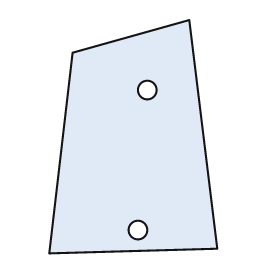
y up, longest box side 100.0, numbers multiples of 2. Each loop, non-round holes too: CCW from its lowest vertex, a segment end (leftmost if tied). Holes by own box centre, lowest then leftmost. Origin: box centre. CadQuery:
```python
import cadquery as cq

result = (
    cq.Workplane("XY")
    .moveTo(-36.0, -50.0)
    .lineTo(36.0, -48.0)
    .lineTo(24.0, 50.0)
    .lineTo(-26.0, 36.0)
    .close()
    .moveTo(2.0, -40.0)
    .circle(4.0)
    .moveTo(6.0, 20.0)
    .circle(4.0)
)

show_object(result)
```